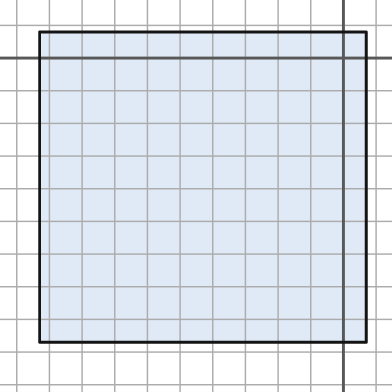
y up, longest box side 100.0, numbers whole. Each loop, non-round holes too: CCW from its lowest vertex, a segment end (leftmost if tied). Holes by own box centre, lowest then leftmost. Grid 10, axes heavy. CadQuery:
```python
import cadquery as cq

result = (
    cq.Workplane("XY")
    .moveTo(-93.0, -87.0)
    .lineTo(7.0, -87.0)
    .lineTo(7.0, 8.0)
    .lineTo(-93.0, 8.0)
    .close()
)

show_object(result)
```